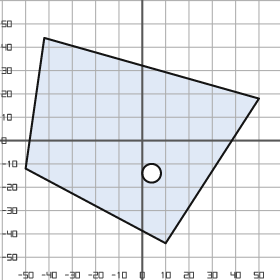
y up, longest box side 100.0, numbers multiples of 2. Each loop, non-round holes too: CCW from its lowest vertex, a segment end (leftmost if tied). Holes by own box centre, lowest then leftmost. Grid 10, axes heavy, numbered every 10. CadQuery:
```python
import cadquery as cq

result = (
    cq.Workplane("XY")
    .moveTo(10.0, -44.0)
    .lineTo(50.0, 18.0)
    .lineTo(-42.0, 44.0)
    .lineTo(-50.0, -12.0)
    .close()
    .moveTo(4.0, -14.0)
    .circle(4.0)
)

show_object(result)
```